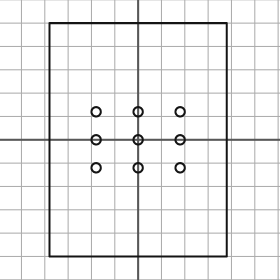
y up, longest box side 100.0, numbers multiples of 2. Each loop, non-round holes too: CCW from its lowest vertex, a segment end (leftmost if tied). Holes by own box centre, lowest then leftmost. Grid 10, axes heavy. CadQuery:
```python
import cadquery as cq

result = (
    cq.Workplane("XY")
    .moveTo(-38.0, -50.0)
    .lineTo(38.0, -50.0)
    .lineTo(38.0, 50.0)
    .lineTo(-38.0, 50.0)
    .close()
    .moveTo(-18.0, -12.0)
    .circle(2.0)
    .moveTo(0.0, -12.0)
    .circle(2.0)
    .moveTo(18.0, -12.0)
    .circle(2.0)
    .moveTo(-18.0, 0.0)
    .circle(2.0)
    .moveTo(0.0, 0.0)
    .circle(2.0)
    .moveTo(18.0, 0.0)
    .circle(2.0)
    .moveTo(-18.0, 12.0)
    .circle(2.0)
    .moveTo(0.0, 12.0)
    .circle(2.0)
    .moveTo(18.0, 12.0)
    .circle(2.0)
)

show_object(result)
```